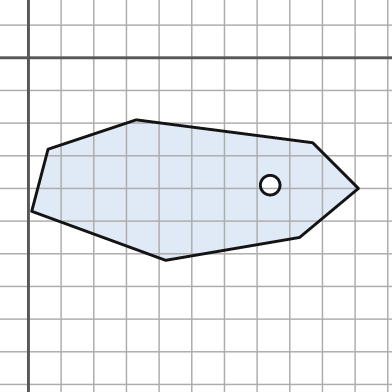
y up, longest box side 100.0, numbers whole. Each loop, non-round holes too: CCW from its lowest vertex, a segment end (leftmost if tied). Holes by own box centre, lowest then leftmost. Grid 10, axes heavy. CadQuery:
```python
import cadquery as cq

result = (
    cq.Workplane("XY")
    .moveTo(42.0, -62.0)
    .lineTo(83.0, -55.0)
    .lineTo(101.0, -40.0)
    .lineTo(87.0, -26.0)
    .lineTo(33.0, -19.0)
    .lineTo(6.0, -28.0)
    .lineTo(1.0, -47.0)
    .close()
    .moveTo(74.0, -39.0)
    .circle(3.0)
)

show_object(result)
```